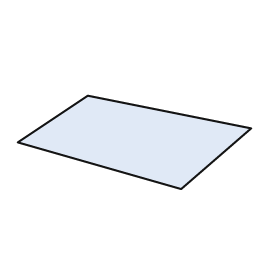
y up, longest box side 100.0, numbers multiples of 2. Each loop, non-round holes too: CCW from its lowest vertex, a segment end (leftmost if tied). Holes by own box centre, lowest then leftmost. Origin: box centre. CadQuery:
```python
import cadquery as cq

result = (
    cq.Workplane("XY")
    .moveTo(20.0, -20.0)
    .lineTo(50.0, 6.0)
    .lineTo(-20.0, 20.0)
    .lineTo(-50.0, 0.0)
    .close()
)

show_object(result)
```